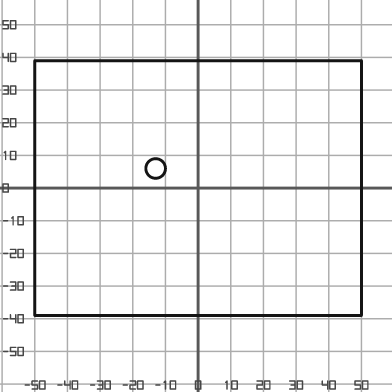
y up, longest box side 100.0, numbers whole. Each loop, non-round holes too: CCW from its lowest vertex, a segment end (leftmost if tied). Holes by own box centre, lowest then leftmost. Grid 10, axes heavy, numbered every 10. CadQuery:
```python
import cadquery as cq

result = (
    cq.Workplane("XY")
    .moveTo(-50.0, -39.0)
    .lineTo(50.0, -39.0)
    .lineTo(50.0, 39.0)
    .lineTo(-50.0, 39.0)
    .close()
    .moveTo(-13.0, 6.0)
    .circle(3.0)
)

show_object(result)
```